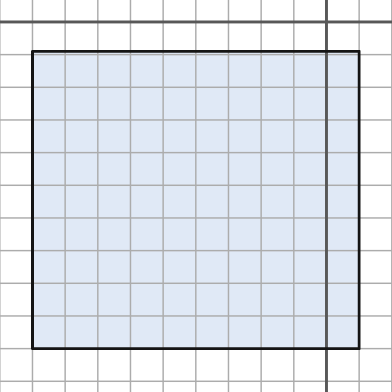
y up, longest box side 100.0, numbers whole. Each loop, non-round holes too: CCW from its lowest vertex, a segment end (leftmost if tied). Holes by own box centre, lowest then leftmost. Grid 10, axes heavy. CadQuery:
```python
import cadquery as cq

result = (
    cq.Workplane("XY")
    .moveTo(-90.0, -100.0)
    .lineTo(10.0, -100.0)
    .lineTo(10.0, -9.0)
    .lineTo(-90.0, -9.0)
    .close()
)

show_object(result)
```